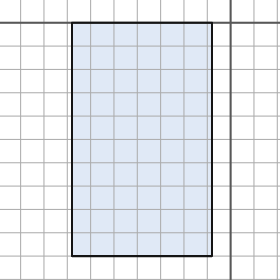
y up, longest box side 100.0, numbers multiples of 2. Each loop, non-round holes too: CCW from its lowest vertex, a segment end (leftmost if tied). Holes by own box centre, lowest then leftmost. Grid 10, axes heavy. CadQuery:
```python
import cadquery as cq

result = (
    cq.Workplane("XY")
    .moveTo(-68.0, -100.0)
    .lineTo(-8.0, -100.0)
    .lineTo(-8.0, 0.0)
    .lineTo(-68.0, 0.0)
    .close()
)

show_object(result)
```